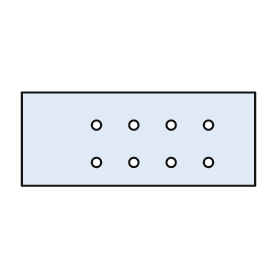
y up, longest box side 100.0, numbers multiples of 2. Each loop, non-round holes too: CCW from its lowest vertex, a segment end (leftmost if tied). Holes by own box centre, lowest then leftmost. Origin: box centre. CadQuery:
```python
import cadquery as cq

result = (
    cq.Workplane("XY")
    .moveTo(-50.0, -20.0)
    .lineTo(50.0, -20.0)
    .lineTo(50.0, 20.0)
    .lineTo(-50.0, 20.0)
    .close()
    .moveTo(-18.0, -10.0)
    .circle(2.0)
    .moveTo(-2.0, -10.0)
    .circle(2.0)
    .moveTo(14.0, -10.0)
    .circle(2.0)
    .moveTo(30.0, -10.0)
    .circle(2.0)
    .moveTo(-18.0, 6.0)
    .circle(2.0)
    .moveTo(-2.0, 6.0)
    .circle(2.0)
    .moveTo(14.0, 6.0)
    .circle(2.0)
    .moveTo(30.0, 6.0)
    .circle(2.0)
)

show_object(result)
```